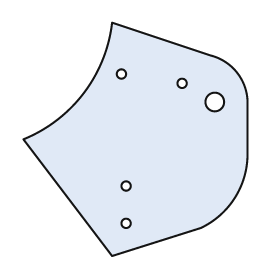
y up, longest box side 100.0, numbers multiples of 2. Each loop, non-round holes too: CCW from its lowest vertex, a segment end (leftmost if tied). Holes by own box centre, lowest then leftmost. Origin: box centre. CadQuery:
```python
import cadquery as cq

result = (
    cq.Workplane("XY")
    .moveTo(-10.0, -50.0)
    .lineTo(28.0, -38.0)
    .threePointArc((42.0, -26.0), (48.0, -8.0))
    .lineTo(48.0, 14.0)
    .threePointArc((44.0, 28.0), (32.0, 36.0))
    .lineTo(-10.0, 50.0)
    .threePointArc((-22.0, 20.0), (-48.0, 0.0))
    .close()
    .moveTo(-4.0, -36.0)
    .circle(2.0)
    .moveTo(-4.0, -20.0)
    .circle(2.0)
    .moveTo(34.0, 16.0)
    .circle(4.0)
    .moveTo(20.0, 24.0)
    .circle(2.0)
    .moveTo(-6.0, 28.0)
    .circle(2.0)
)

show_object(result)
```